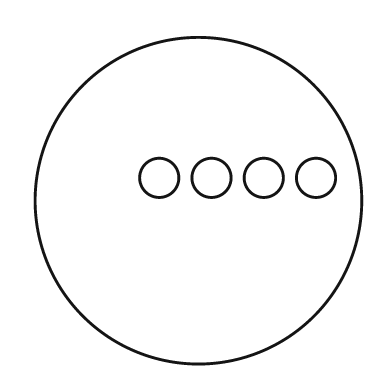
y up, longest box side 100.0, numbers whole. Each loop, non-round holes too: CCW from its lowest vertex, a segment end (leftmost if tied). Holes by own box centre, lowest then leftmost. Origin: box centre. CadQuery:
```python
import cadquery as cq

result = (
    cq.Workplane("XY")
    .moveTo(0.0, 0.0)
    .circle(50.0)
    .moveTo(-12.0, 7.0)
    .circle(6.0)
    .moveTo(4.0, 7.0)
    .circle(6.0)
    .moveTo(20.0, 7.0)
    .circle(6.0)
    .moveTo(36.0, 7.0)
    .circle(6.0)
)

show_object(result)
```